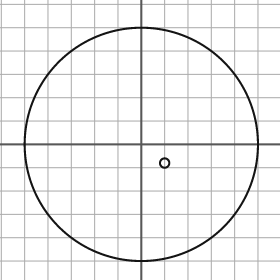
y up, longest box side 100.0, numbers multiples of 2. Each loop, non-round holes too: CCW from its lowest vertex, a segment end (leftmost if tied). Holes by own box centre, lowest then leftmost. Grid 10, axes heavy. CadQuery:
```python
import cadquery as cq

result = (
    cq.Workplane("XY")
    .moveTo(0.0, 0.0)
    .circle(50.0)
    .moveTo(10.0, -8.0)
    .circle(2.0)
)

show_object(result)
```